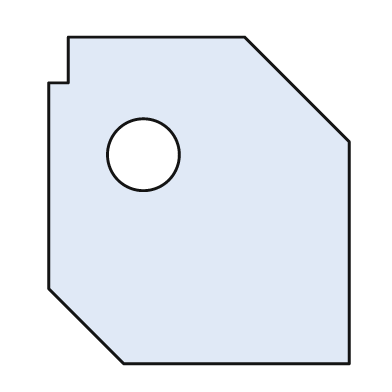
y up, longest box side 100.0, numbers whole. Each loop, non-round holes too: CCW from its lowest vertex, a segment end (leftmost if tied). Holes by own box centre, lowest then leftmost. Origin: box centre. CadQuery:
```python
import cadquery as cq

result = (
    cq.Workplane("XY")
    .moveTo(-23.0, -50.0)
    .lineTo(46.0, -50.0)
    .lineTo(46.0, 18.0)
    .lineTo(14.0, 50.0)
    .lineTo(-40.0, 50.0)
    .lineTo(-40.0, 36.0)
    .lineTo(-46.0, 36.0)
    .lineTo(-46.0, -27.0)
    .close()
    .moveTo(-17.0, 14.0)
    .circle(11.0)
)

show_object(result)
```